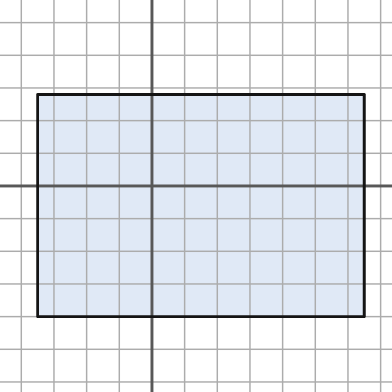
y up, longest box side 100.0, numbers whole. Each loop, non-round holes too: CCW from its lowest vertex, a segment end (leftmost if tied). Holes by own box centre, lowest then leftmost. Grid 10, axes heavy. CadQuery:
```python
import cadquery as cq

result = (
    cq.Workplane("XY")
    .moveTo(-35.0, -40.0)
    .lineTo(65.0, -40.0)
    .lineTo(65.0, 28.0)
    .lineTo(-35.0, 28.0)
    .close()
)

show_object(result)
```